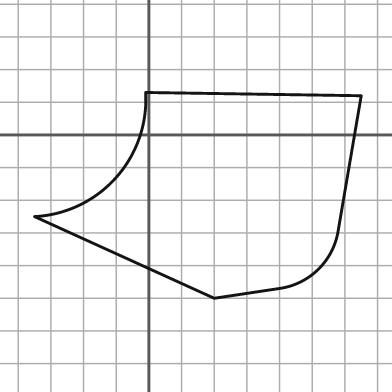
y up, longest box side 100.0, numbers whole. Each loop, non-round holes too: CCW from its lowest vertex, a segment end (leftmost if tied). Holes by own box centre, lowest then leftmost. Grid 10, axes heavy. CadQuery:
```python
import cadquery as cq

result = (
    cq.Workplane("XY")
    .moveTo(20.0, -50.0)
    .lineTo(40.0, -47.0)
    .threePointArc((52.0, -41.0), (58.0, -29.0))
    .lineTo(65.0, 12.0)
    .lineTo(-1.0, 13.0)
    .threePointArc((-10.0, -13.0), (-35.0, -25.0))
    .close()
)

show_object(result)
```